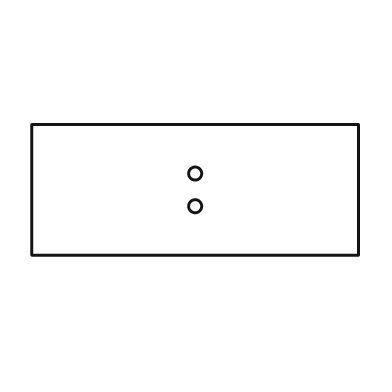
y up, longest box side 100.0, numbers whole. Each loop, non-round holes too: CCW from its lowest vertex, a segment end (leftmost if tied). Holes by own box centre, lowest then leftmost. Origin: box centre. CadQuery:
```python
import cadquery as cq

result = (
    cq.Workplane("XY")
    .moveTo(-50.0, -20.0)
    .lineTo(50.0, -20.0)
    .lineTo(50.0, 20.0)
    .lineTo(-50.0, 20.0)
    .close()
    .moveTo(0.0, -5.0)
    .circle(2.0)
    .moveTo(0.0, 5.0)
    .circle(2.0)
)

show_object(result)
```